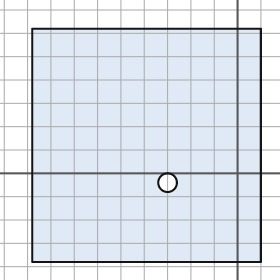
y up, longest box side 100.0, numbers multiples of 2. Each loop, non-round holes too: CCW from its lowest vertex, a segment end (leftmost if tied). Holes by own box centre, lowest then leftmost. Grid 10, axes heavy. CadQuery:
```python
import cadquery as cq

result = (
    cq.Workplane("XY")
    .moveTo(-88.0, -38.0)
    .lineTo(10.0, -38.0)
    .lineTo(10.0, 62.0)
    .lineTo(-88.0, 62.0)
    .close()
    .moveTo(-30.0, -4.0)
    .circle(4.0)
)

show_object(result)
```